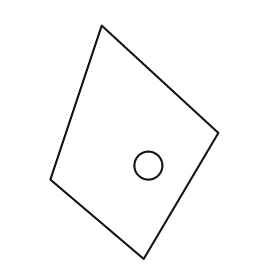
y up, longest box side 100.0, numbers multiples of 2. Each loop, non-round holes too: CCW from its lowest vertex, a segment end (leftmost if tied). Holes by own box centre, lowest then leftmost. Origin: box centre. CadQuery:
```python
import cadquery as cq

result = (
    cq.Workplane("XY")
    .moveTo(4.0, -50.0)
    .lineTo(36.0, 4.0)
    .lineTo(-14.0, 50.0)
    .lineTo(-36.0, -16.0)
    .close()
    .moveTo(6.0, -10.0)
    .circle(6.0)
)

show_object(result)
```